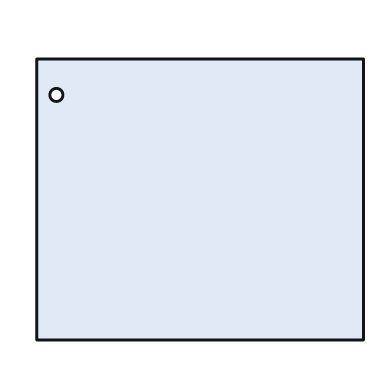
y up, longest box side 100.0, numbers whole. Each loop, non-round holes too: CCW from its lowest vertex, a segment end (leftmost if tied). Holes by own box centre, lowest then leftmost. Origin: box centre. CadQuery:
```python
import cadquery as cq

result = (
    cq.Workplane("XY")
    .moveTo(-50.0, -43.0)
    .lineTo(50.0, -43.0)
    .lineTo(50.0, 43.0)
    .lineTo(-50.0, 43.0)
    .close()
    .moveTo(-44.0, 32.0)
    .circle(2.0)
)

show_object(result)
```